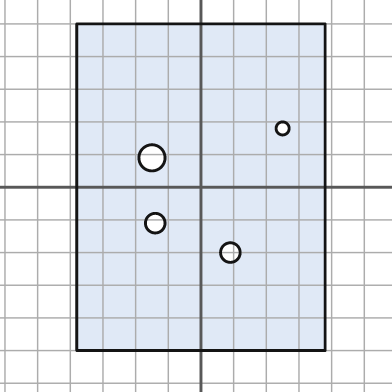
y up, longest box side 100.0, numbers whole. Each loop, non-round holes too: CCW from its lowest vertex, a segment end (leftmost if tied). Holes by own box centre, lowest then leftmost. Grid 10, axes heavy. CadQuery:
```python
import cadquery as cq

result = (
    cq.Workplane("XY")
    .moveTo(-38.0, -50.0)
    .lineTo(38.0, -50.0)
    .lineTo(38.0, 50.0)
    .lineTo(-38.0, 50.0)
    .close()
    .moveTo(9.0, -20.0)
    .circle(3.0)
    .moveTo(-14.0, -11.0)
    .circle(3.0)
    .moveTo(-15.0, 9.0)
    .circle(4.0)
    .moveTo(25.0, 18.0)
    .circle(2.0)
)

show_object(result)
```